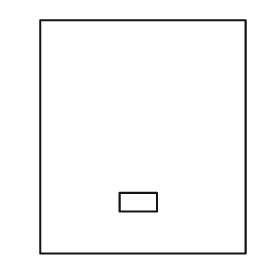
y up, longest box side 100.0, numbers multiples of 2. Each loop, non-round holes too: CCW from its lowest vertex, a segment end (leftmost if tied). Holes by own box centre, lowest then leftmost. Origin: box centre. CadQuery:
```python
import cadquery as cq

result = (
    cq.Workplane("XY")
    .moveTo(-44.0, -50.0)
    .lineTo(44.0, -50.0)
    .lineTo(44.0, 50.0)
    .lineTo(-44.0, 50.0)
    .close()
    .moveTo(-10.0, -32.0)
    .lineTo(6.0, -32.0)
    .lineTo(6.0, -24.0)
    .lineTo(-10.0, -24.0)
    .close()
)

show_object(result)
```